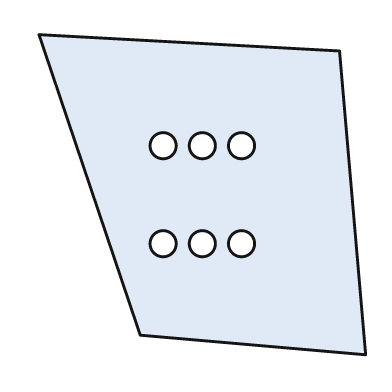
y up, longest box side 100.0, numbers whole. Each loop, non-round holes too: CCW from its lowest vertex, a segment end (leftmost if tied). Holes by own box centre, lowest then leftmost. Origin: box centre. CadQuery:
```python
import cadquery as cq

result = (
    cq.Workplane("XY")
    .moveTo(50.0, -49.0)
    .lineTo(42.0, 44.0)
    .lineTo(-50.0, 49.0)
    .lineTo(-19.0, -43.0)
    .close()
    .moveTo(-12.0, -15.0)
    .circle(4.0)
    .moveTo(0.0, -15.0)
    .circle(4.0)
    .moveTo(12.0, -15.0)
    .circle(4.0)
    .moveTo(-12.0, 15.0)
    .circle(4.0)
    .moveTo(0.0, 15.0)
    .circle(4.0)
    .moveTo(12.0, 15.0)
    .circle(4.0)
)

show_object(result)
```